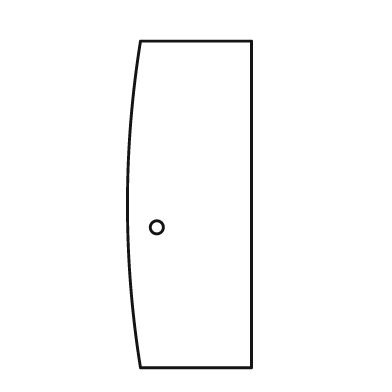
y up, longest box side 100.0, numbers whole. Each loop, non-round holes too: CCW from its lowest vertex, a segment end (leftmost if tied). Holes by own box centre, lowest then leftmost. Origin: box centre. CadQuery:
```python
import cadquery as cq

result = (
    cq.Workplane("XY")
    .moveTo(-15.0, -50.0)
    .lineTo(19.0, -50.0)
    .lineTo(19.0, 50.0)
    .lineTo(-15.0, 50.0)
    .threePointArc((-19.0, 0.0), (-15.0, -50.0))
    .close()
    .moveTo(-10.0, -7.0)
    .circle(2.0)
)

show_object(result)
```